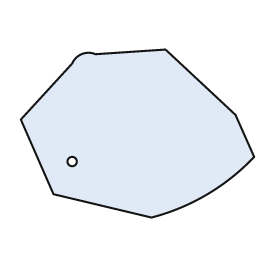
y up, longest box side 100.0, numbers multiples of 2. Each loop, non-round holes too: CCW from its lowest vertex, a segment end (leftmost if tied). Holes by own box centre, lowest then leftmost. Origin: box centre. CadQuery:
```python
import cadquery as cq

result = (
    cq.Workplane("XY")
    .moveTo(6.0, -36.0)
    .threePointArc((30.0, -26.0), (50.0, -10.0))
    .lineTo(42.0, 8.0)
    .lineTo(12.0, 36.0)
    .lineTo(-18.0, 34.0)
    .threePointArc((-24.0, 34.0), (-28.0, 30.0))
    .lineTo(-50.0, 6.0)
    .lineTo(-36.0, -26.0)
    .close()
    .moveTo(-28.0, -12.0)
    .circle(2.0)
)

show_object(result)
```